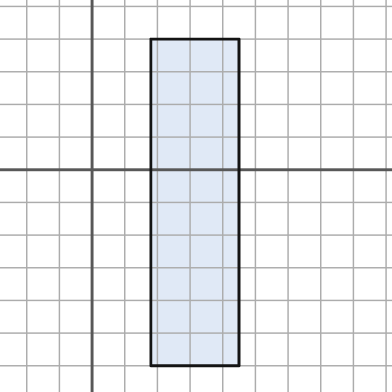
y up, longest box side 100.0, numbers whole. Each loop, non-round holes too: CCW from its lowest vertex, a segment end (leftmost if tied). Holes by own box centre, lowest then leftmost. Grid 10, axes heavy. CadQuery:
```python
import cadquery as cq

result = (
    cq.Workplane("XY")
    .moveTo(18.0, -60.0)
    .lineTo(45.0, -60.0)
    .lineTo(45.0, 40.0)
    .lineTo(18.0, 40.0)
    .close()
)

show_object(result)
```